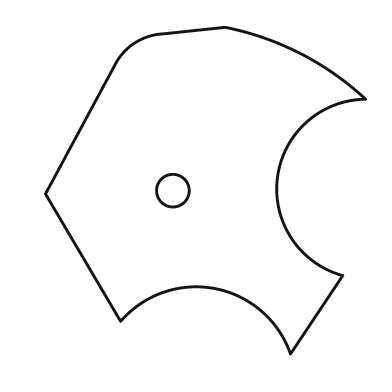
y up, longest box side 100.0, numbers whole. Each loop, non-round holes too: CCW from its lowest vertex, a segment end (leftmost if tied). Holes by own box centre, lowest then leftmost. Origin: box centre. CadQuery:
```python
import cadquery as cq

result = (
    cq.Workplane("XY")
    .moveTo(26.0, -50.0)
    .lineTo(42.0, -26.0)
    .threePointArc((22.0, 4.0), (49.0, 28.0))
    .threePointArc((29.0, 42.0), (6.0, 50.0))
    .lineTo(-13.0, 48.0)
    .threePointArc((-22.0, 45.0), (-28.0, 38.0))
    .lineTo(-49.0, -1.0)
    .lineTo(-26.0, -40.0)
    .threePointArc((3.0, -30.0), (26.0, -50.0))
    .close()
    .moveTo(-10.0, 0.0)
    .circle(5.0)
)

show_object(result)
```